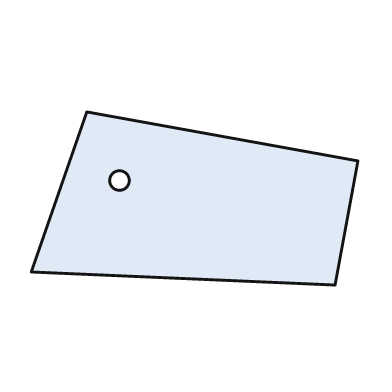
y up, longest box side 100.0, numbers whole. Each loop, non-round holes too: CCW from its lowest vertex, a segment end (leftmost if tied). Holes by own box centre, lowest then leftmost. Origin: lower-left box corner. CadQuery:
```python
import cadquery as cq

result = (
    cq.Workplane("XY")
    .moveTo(93.0, 0.0)
    .lineTo(100.0, 38.0)
    .lineTo(17.0, 53.0)
    .lineTo(0.0, 4.0)
    .close()
    .moveTo(27.0, 32.0)
    .circle(3.0)
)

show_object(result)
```